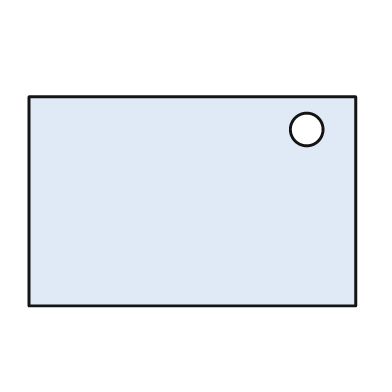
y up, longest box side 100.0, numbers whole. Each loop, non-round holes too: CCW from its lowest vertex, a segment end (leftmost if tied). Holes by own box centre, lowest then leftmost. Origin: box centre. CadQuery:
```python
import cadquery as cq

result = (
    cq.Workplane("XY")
    .moveTo(-50.0, -32.0)
    .lineTo(50.0, -32.0)
    .lineTo(50.0, 32.0)
    .lineTo(-50.0, 32.0)
    .close()
    .moveTo(35.0, 22.0)
    .circle(5.0)
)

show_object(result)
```